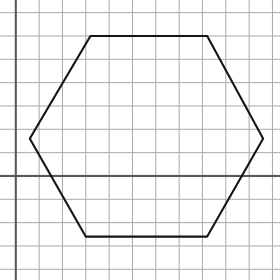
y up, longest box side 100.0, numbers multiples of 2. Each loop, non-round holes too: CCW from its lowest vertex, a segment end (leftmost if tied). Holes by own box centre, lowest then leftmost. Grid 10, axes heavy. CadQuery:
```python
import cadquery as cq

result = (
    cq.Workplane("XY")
    .moveTo(30.0, -26.0)
    .lineTo(82.0, -26.0)
    .lineTo(106.0, 16.0)
    .lineTo(82.0, 60.0)
    .lineTo(32.0, 60.0)
    .lineTo(6.0, 16.0)
    .close()
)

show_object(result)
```